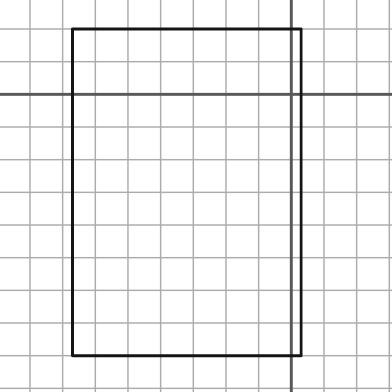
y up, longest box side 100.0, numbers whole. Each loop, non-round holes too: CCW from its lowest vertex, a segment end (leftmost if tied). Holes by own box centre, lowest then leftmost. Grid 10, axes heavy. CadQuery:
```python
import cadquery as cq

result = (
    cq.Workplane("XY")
    .moveTo(-67.0, -80.0)
    .lineTo(3.0, -80.0)
    .lineTo(3.0, 20.0)
    .lineTo(-67.0, 20.0)
    .close()
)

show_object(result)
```